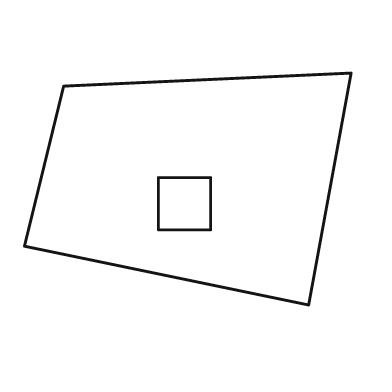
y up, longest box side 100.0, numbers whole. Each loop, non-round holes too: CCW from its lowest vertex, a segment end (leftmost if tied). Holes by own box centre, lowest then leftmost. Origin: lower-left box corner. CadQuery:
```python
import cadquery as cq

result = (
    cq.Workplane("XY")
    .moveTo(87.0, 0.0)
    .lineTo(100.0, 71.0)
    .lineTo(12.0, 67.0)
    .lineTo(0.0, 18.0)
    .close()
    .moveTo(41.0, 23.0)
    .lineTo(57.0, 23.0)
    .lineTo(57.0, 39.0)
    .lineTo(41.0, 39.0)
    .close()
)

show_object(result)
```